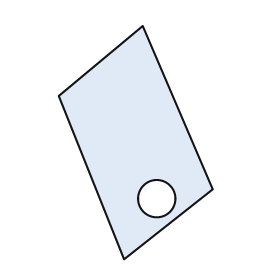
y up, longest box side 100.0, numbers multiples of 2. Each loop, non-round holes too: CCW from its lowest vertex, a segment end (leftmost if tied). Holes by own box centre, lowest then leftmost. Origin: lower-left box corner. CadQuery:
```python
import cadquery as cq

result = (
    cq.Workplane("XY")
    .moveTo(28.0, 0.0)
    .lineTo(66.0, 30.0)
    .lineTo(36.0, 100.0)
    .lineTo(0.0, 70.0)
    .close()
    .moveTo(42.0, 26.0)
    .circle(8.0)
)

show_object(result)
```